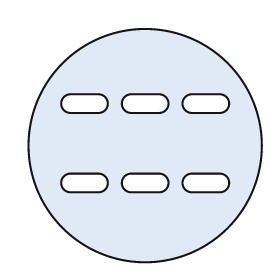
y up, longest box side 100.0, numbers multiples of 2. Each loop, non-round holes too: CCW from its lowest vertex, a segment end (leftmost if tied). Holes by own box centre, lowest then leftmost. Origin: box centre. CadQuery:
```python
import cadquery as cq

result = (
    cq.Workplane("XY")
    .moveTo(0.0, 0.0)
    .circle(50.0)
    .moveTo(-32.0, -20.0)
    .lineTo(-20.0, -20.0)
    .threePointArc((-16.0, -16.0), (-20.0, -12.0))
    .lineTo(-32.0, -12.0)
    .threePointArc((-36.0, -16.0), (-32.0, -20.0))
    .close()
    .moveTo(-6.0, -20.0)
    .lineTo(6.0, -20.0)
    .threePointArc((10.0, -16.0), (6.0, -12.0))
    .lineTo(-6.0, -12.0)
    .threePointArc((-10.0, -16.0), (-6.0, -20.0))
    .close()
    .moveTo(20.0, -20.0)
    .lineTo(32.0, -20.0)
    .threePointArc((36.0, -16.0), (32.0, -12.0))
    .lineTo(20.0, -12.0)
    .threePointArc((16.0, -16.0), (20.0, -20.0))
    .close()
    .moveTo(-32.0, 14.0)
    .lineTo(-20.0, 14.0)
    .threePointArc((-16.0, 18.0), (-20.0, 22.0))
    .lineTo(-32.0, 22.0)
    .threePointArc((-36.0, 18.0), (-32.0, 14.0))
    .close()
    .moveTo(-6.0, 14.0)
    .lineTo(6.0, 14.0)
    .threePointArc((10.0, 18.0), (6.0, 22.0))
    .lineTo(-6.0, 22.0)
    .threePointArc((-10.0, 18.0), (-6.0, 14.0))
    .close()
    .moveTo(20.0, 14.0)
    .lineTo(32.0, 14.0)
    .threePointArc((36.0, 18.0), (32.0, 22.0))
    .lineTo(20.0, 22.0)
    .threePointArc((16.0, 18.0), (20.0, 14.0))
    .close()
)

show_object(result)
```